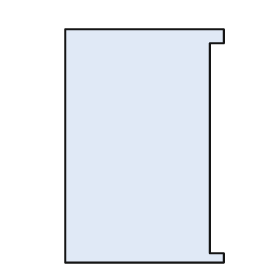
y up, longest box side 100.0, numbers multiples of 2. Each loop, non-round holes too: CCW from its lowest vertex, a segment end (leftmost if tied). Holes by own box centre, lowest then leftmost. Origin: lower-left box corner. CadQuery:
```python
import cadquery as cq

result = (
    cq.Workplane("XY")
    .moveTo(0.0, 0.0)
    .lineTo(68.0, 0.0)
    .lineTo(68.0, 4.0)
    .lineTo(62.0, 4.0)
    .lineTo(62.0, 94.0)
    .lineTo(68.0, 94.0)
    .lineTo(68.0, 100.0)
    .lineTo(0.0, 100.0)
    .close()
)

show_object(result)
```